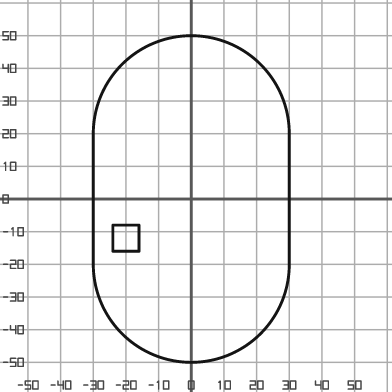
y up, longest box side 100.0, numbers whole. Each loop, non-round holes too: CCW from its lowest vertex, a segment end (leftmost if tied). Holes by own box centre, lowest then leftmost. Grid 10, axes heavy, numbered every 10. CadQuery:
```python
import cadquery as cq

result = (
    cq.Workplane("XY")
    .moveTo(-30.0, -20.0)
    .threePointArc((0.0, -50.0), (30.0, -20.0))
    .lineTo(30.0, 20.0)
    .threePointArc((0.0, 50.0), (-30.0, 20.0))
    .close()
    .moveTo(-24.0, -16.0)
    .lineTo(-16.0, -16.0)
    .lineTo(-16.0, -8.0)
    .lineTo(-24.0, -8.0)
    .close()
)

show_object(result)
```